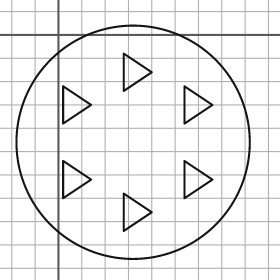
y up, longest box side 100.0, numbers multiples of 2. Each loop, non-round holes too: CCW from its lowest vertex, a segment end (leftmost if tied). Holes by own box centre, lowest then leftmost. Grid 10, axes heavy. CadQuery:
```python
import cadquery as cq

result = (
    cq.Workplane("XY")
    .moveTo(32.0, -46.0)
    .circle(50.0)
    .moveTo(28.0, -84.0)
    .lineTo(40.0, -76.0)
    .lineTo(28.0, -68.0)
    .close()
    .moveTo(2.0, -70.0)
    .lineTo(14.0, -62.0)
    .lineTo(2.0, -54.0)
    .close()
    .moveTo(54.0, -70.0)
    .lineTo(66.0, -62.0)
    .lineTo(54.0, -54.0)
    .close()
    .moveTo(2.0, -38.0)
    .lineTo(14.0, -30.0)
    .lineTo(2.0, -22.0)
    .close()
    .moveTo(54.0, -38.0)
    .lineTo(66.0, -30.0)
    .lineTo(54.0, -22.0)
    .close()
    .moveTo(28.0, -24.0)
    .lineTo(40.0, -16.0)
    .lineTo(28.0, -8.0)
    .close()
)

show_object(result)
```